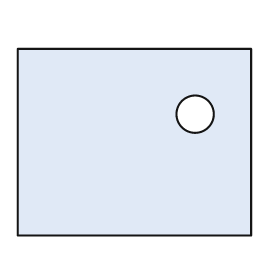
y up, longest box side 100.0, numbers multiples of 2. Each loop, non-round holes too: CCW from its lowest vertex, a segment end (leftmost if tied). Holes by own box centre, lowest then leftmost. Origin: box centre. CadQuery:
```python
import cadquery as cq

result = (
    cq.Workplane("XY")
    .moveTo(-50.0, -40.0)
    .lineTo(50.0, -40.0)
    .lineTo(50.0, 40.0)
    .lineTo(-50.0, 40.0)
    .close()
    .moveTo(26.0, 12.0)
    .circle(8.0)
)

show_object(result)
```